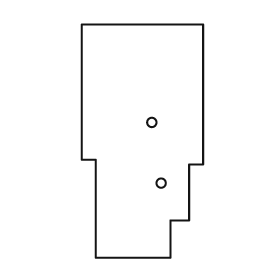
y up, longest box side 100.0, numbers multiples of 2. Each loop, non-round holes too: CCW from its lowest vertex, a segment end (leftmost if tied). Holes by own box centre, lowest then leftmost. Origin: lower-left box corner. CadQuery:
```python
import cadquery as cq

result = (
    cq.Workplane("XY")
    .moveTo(6.0, 0.0)
    .lineTo(38.0, 0.0)
    .lineTo(38.0, 16.0)
    .lineTo(46.0, 16.0)
    .lineTo(46.0, 40.0)
    .lineTo(52.0, 40.0)
    .lineTo(52.0, 100.0)
    .lineTo(0.0, 100.0)
    .lineTo(0.0, 42.0)
    .lineTo(6.0, 42.0)
    .close()
    .moveTo(34.0, 32.0)
    .circle(2.0)
    .moveTo(30.0, 58.0)
    .circle(2.0)
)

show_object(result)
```